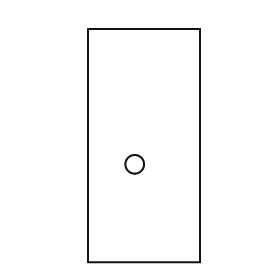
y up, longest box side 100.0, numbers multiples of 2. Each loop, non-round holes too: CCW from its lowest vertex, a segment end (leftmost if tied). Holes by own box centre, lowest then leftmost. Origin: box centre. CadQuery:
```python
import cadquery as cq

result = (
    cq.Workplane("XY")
    .moveTo(-24.0, -50.0)
    .lineTo(24.0, -50.0)
    .lineTo(24.0, 50.0)
    .lineTo(-24.0, 50.0)
    .close()
    .moveTo(-4.0, -8.0)
    .circle(4.0)
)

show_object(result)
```